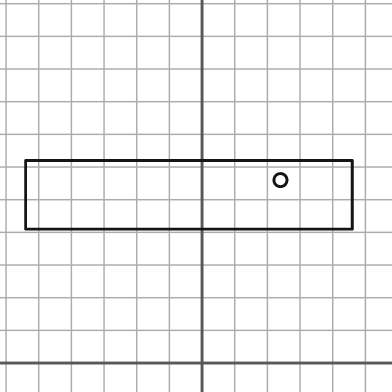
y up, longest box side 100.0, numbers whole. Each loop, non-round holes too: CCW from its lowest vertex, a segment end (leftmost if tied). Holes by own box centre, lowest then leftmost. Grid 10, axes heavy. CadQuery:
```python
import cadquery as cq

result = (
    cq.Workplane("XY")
    .moveTo(-54.0, 41.0)
    .lineTo(46.0, 41.0)
    .lineTo(46.0, 62.0)
    .lineTo(-54.0, 62.0)
    .close()
    .moveTo(24.0, 56.0)
    .circle(2.0)
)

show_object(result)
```